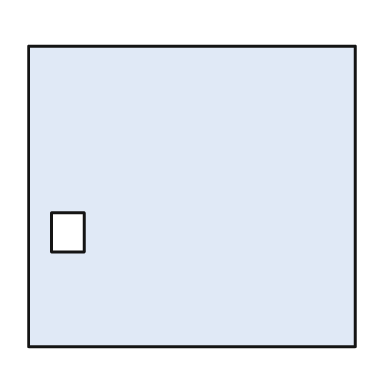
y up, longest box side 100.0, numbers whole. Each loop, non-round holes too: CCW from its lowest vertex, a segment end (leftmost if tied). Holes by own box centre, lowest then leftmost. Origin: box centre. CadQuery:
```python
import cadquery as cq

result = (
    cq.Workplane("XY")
    .moveTo(-50.0, -46.0)
    .lineTo(50.0, -46.0)
    .lineTo(50.0, 46.0)
    .lineTo(-50.0, 46.0)
    .close()
    .moveTo(-43.0, -17.0)
    .lineTo(-33.0, -17.0)
    .lineTo(-33.0, -5.0)
    .lineTo(-43.0, -5.0)
    .close()
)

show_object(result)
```